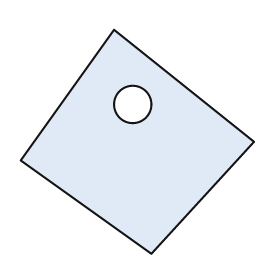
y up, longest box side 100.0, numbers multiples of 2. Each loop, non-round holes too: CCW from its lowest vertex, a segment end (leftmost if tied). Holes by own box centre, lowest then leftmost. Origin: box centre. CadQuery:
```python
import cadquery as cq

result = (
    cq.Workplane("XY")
    .moveTo(6.0, -48.0)
    .lineTo(50.0, 0.0)
    .lineTo(-10.0, 48.0)
    .lineTo(-50.0, -8.0)
    .close()
    .moveTo(-2.0, 16.0)
    .circle(8.0)
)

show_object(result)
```